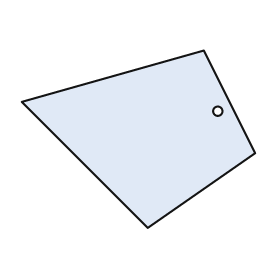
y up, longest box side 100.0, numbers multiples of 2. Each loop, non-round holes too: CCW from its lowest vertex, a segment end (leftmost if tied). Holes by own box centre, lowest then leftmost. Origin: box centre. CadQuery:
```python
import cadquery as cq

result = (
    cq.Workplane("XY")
    .moveTo(4.0, -38.0)
    .lineTo(50.0, -6.0)
    .lineTo(28.0, 38.0)
    .lineTo(-50.0, 16.0)
    .close()
    .moveTo(34.0, 12.0)
    .circle(2.0)
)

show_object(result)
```